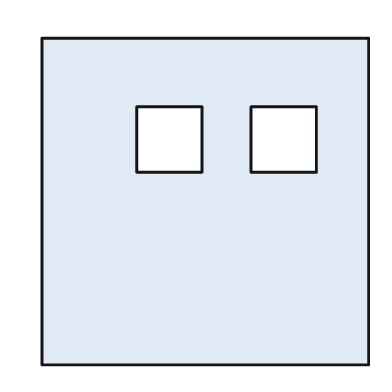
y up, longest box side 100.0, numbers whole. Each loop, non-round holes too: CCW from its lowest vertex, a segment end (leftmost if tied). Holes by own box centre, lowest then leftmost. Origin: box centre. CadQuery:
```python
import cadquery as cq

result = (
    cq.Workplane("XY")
    .moveTo(-50.0, -50.0)
    .lineTo(50.0, -50.0)
    .lineTo(50.0, 50.0)
    .lineTo(-50.0, 50.0)
    .close()
    .moveTo(-21.0, 9.0)
    .lineTo(-1.0, 9.0)
    .lineTo(-1.0, 29.0)
    .lineTo(-21.0, 29.0)
    .close()
    .moveTo(14.0, 9.0)
    .lineTo(34.0, 9.0)
    .lineTo(34.0, 29.0)
    .lineTo(14.0, 29.0)
    .close()
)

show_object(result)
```